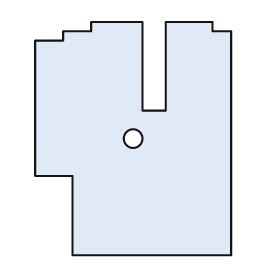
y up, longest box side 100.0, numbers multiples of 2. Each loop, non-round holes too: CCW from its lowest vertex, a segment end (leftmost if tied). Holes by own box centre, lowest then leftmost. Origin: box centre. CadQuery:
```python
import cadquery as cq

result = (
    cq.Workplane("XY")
    .moveTo(-26.0, -50.0)
    .lineTo(42.0, -50.0)
    .lineTo(42.0, 46.0)
    .lineTo(34.0, 46.0)
    .lineTo(34.0, 50.0)
    .lineTo(14.0, 50.0)
    .lineTo(14.0, 12.0)
    .lineTo(4.0, 12.0)
    .lineTo(4.0, 50.0)
    .lineTo(-18.0, 50.0)
    .lineTo(-18.0, 46.0)
    .lineTo(-30.0, 46.0)
    .lineTo(-30.0, 42.0)
    .lineTo(-42.0, 42.0)
    .lineTo(-42.0, -16.0)
    .lineTo(-26.0, -16.0)
    .close()
    .moveTo(0.0, 0.0)
    .circle(4.0)
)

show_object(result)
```